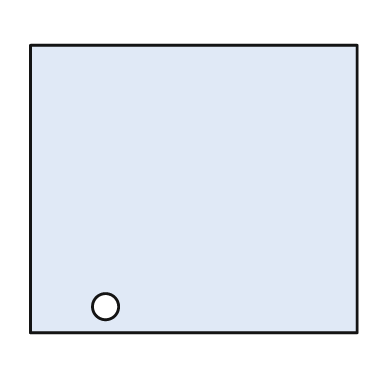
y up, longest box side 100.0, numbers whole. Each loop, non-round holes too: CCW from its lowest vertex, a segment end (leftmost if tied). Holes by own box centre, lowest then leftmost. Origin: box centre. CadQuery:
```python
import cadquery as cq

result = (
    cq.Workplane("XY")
    .moveTo(-50.0, -44.0)
    .lineTo(50.0, -44.0)
    .lineTo(50.0, 44.0)
    .lineTo(-50.0, 44.0)
    .close()
    .moveTo(-27.0, -36.0)
    .circle(4.0)
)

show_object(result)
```